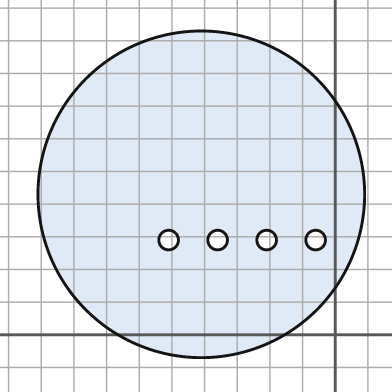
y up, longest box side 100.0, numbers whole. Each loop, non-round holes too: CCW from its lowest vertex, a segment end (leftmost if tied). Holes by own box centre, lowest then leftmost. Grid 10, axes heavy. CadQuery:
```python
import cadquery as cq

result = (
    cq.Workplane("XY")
    .moveTo(-41.0, 43.0)
    .circle(50.0)
    .moveTo(-51.0, 29.0)
    .circle(3.0)
    .moveTo(-36.0, 29.0)
    .circle(3.0)
    .moveTo(-21.0, 29.0)
    .circle(3.0)
    .moveTo(-6.0, 29.0)
    .circle(3.0)
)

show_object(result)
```